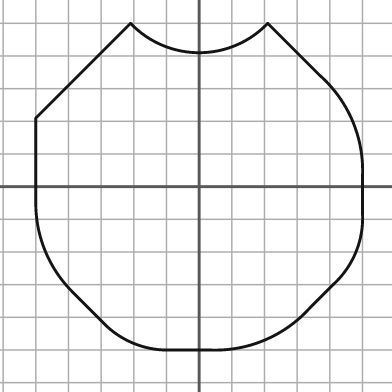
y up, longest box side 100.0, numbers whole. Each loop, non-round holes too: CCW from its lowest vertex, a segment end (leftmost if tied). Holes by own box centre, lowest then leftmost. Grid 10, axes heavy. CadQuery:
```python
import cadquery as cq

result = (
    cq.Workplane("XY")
    .moveTo(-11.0, -50.0)
    .lineTo(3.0, -50.0)
    .threePointArc((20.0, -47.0), (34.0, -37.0))
    .lineTo(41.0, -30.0)
    .threePointArc((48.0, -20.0), (50.0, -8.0))
    .lineTo(50.0, 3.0)
    .threePointArc((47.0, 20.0), (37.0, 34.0))
    .lineTo(21.0, 50.0)
    .threePointArc((0.0, 41.0), (-21.0, 50.0))
    .lineTo(-50.0, 21.0)
    .lineTo(-50.0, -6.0)
    .threePointArc((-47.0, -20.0), (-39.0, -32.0))
    .lineTo(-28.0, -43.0)
    .threePointArc((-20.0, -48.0), (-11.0, -50.0))
    .close()
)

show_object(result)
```